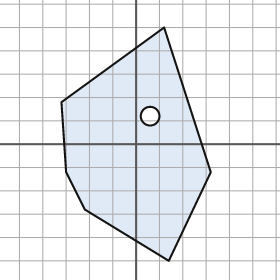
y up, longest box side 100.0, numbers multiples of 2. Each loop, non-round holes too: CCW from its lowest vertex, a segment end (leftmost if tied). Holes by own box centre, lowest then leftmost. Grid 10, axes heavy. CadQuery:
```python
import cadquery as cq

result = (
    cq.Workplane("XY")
    .moveTo(14.0, -50.0)
    .lineTo(32.0, -12.0)
    .lineTo(12.0, 50.0)
    .lineTo(-32.0, 18.0)
    .lineTo(-30.0, -12.0)
    .lineTo(-22.0, -28.0)
    .close()
    .moveTo(6.0, 12.0)
    .circle(4.0)
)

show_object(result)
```